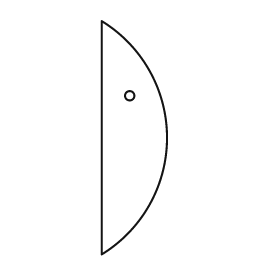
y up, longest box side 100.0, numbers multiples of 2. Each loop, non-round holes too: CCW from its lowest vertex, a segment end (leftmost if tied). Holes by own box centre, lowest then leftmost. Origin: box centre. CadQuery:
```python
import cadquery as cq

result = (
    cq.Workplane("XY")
    .moveTo(-14.0, -50.0)
    .threePointArc((14.0, 0.0), (-14.0, 50.0))
    .close()
    .moveTo(-2.0, 18.0)
    .circle(2.0)
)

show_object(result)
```